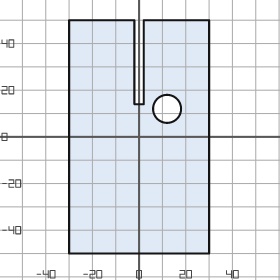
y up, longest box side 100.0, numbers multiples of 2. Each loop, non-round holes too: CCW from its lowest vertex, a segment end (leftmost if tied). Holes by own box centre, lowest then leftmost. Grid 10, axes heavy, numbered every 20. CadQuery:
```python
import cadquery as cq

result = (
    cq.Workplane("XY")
    .moveTo(-30.0, -50.0)
    .lineTo(30.0, -50.0)
    .lineTo(30.0, 50.0)
    .lineTo(2.0, 50.0)
    .lineTo(2.0, 14.0)
    .lineTo(-2.0, 14.0)
    .lineTo(-2.0, 50.0)
    .lineTo(-30.0, 50.0)
    .close()
    .moveTo(12.0, 12.0)
    .circle(6.0)
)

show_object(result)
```